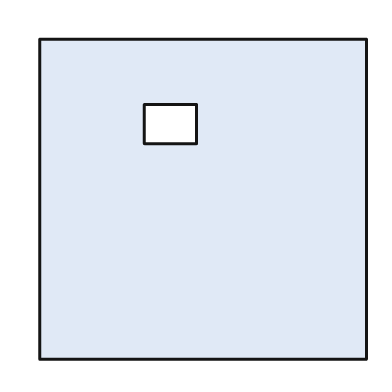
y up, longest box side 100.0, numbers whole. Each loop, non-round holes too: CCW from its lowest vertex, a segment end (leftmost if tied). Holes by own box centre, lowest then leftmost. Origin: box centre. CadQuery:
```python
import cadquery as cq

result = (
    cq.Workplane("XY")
    .moveTo(-50.0, -49.0)
    .lineTo(50.0, -49.0)
    .lineTo(50.0, 49.0)
    .lineTo(-50.0, 49.0)
    .close()
    .moveTo(-18.0, 17.0)
    .lineTo(-2.0, 17.0)
    .lineTo(-2.0, 29.0)
    .lineTo(-18.0, 29.0)
    .close()
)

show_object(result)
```